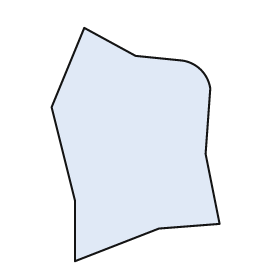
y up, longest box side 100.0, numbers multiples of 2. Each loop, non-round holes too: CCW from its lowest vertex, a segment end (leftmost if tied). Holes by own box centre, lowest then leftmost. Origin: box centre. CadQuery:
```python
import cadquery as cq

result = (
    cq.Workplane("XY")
    .moveTo(-26.0, -50.0)
    .lineTo(10.0, -36.0)
    .lineTo(36.0, -34.0)
    .lineTo(30.0, -4.0)
    .lineTo(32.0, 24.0)
    .threePointArc((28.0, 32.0), (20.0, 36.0))
    .lineTo(0.0, 38.0)
    .lineTo(-22.0, 50.0)
    .lineTo(-36.0, 16.0)
    .lineTo(-26.0, -24.0)
    .close()
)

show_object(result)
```